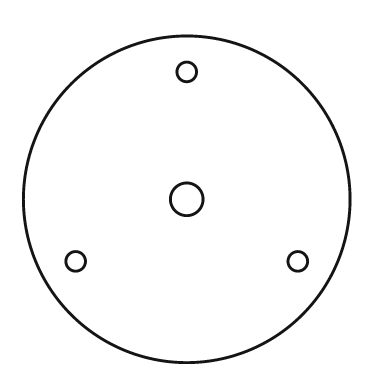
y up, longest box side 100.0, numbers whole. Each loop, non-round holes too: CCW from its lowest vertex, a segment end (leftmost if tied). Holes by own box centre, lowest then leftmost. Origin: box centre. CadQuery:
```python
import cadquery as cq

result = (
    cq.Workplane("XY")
    .moveTo(0.0, 0.0)
    .circle(50.0)
    .moveTo(-34.0, -19.0)
    .circle(3.0)
    .moveTo(34.0, -19.0)
    .circle(3.0)
    .moveTo(0.0, 0.0)
    .circle(5.0)
    .moveTo(0.0, 39.0)
    .circle(3.0)
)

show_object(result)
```